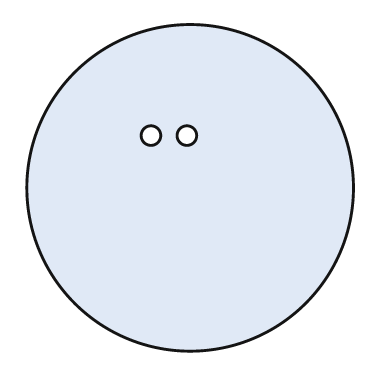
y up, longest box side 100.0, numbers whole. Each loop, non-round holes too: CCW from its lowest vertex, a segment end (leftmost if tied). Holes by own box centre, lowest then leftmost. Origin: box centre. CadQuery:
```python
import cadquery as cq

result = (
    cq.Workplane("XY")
    .moveTo(0.0, 0.0)
    .circle(50.0)
    .moveTo(-12.0, 16.0)
    .circle(3.0)
    .moveTo(-1.0, 16.0)
    .circle(3.0)
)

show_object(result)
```